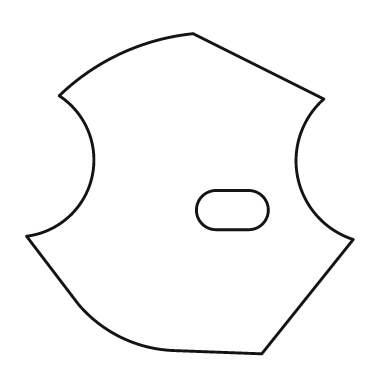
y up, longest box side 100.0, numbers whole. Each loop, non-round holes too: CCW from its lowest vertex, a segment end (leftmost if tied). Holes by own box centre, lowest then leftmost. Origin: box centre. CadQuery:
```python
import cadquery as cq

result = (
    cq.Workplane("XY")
    .moveTo(22.0, -49.0)
    .lineTo(50.0, -14.0)
    .threePointArc((33.0, 5.0), (41.0, 29.0))
    .lineTo(1.0, 49.0)
    .threePointArc((-21.0, 43.0), (-40.0, 30.0))
    .threePointArc((-30.0, 5.0), (-50.0, -13.0))
    .lineTo(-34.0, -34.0)
    .threePointArc((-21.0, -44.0), (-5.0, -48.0))
    .close()
    .moveTo(8.0, -11.0)
    .lineTo(18.0, -11.0)
    .threePointArc((24.0, -5.0), (18.0, 1.0))
    .lineTo(8.0, 1.0)
    .threePointArc((2.0, -5.0), (8.0, -11.0))
    .close()
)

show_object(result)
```